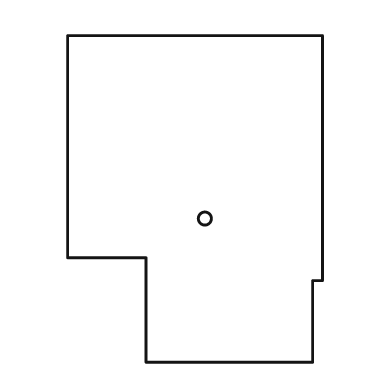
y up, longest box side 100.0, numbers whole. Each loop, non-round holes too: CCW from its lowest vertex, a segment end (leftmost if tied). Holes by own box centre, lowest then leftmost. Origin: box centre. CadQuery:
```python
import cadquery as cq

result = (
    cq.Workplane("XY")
    .moveTo(-15.0, -50.0)
    .lineTo(36.0, -50.0)
    .lineTo(36.0, -25.0)
    .lineTo(39.0, -25.0)
    .lineTo(39.0, 50.0)
    .lineTo(-39.0, 50.0)
    .lineTo(-39.0, -18.0)
    .lineTo(-15.0, -18.0)
    .close()
    .moveTo(3.0, -6.0)
    .circle(2.0)
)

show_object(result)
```